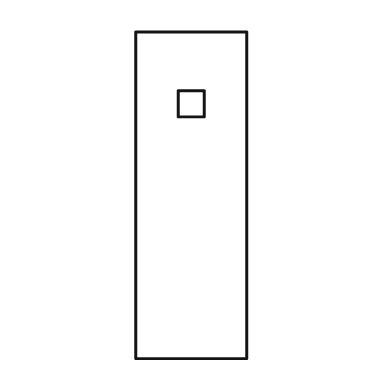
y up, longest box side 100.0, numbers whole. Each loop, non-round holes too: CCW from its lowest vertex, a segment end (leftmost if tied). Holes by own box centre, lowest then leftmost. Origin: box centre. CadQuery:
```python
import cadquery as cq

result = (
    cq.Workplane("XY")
    .moveTo(-17.0, -50.0)
    .lineTo(17.0, -50.0)
    .lineTo(17.0, 50.0)
    .lineTo(-17.0, 50.0)
    .close()
    .moveTo(-4.0, 24.0)
    .lineTo(4.0, 24.0)
    .lineTo(4.0, 32.0)
    .lineTo(-4.0, 32.0)
    .close()
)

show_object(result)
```